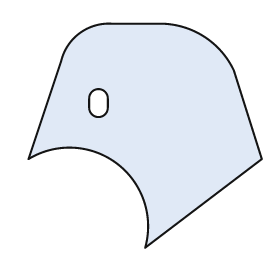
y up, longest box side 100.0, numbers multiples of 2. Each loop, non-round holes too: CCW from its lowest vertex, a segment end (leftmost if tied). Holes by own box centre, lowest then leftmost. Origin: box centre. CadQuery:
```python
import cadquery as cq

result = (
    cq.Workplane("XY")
    .moveTo(0.0, -48.0)
    .lineTo(50.0, -10.0)
    .lineTo(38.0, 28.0)
    .threePointArc((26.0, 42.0), (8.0, 48.0))
    .lineTo(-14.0, 48.0)
    .threePointArc((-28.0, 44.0), (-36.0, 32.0))
    .lineTo(-50.0, -10.0)
    .threePointArc((-12.0, -12.0), (0.0, -48.0))
    .close()
    .moveTo(-24.0, 12.0)
    .threePointArc((-20.0, 8.0), (-16.0, 12.0))
    .lineTo(-16.0, 16.0)
    .threePointArc((-20.0, 20.0), (-24.0, 16.0))
    .close()
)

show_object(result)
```